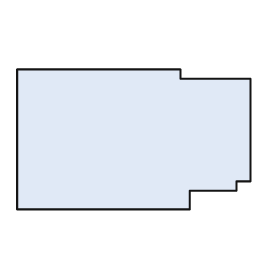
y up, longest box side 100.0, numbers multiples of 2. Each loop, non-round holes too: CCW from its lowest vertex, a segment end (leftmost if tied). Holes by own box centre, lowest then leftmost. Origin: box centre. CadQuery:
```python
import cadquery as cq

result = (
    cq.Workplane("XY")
    .moveTo(-50.0, -30.0)
    .lineTo(24.0, -30.0)
    .lineTo(24.0, -22.0)
    .lineTo(44.0, -22.0)
    .lineTo(44.0, -18.0)
    .lineTo(50.0, -18.0)
    .lineTo(50.0, 26.0)
    .lineTo(20.0, 26.0)
    .lineTo(20.0, 30.0)
    .lineTo(-50.0, 30.0)
    .close()
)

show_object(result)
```